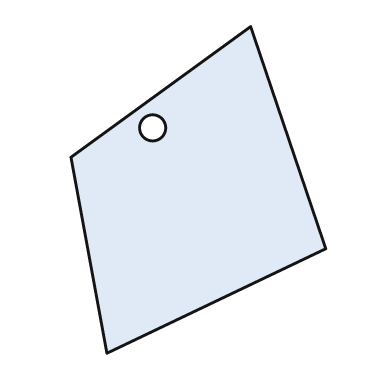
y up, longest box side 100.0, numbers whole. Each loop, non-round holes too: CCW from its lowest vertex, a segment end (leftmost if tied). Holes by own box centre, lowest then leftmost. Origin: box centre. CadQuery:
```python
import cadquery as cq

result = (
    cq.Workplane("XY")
    .moveTo(-28.0, -50.0)
    .lineTo(39.0, -18.0)
    .lineTo(16.0, 50.0)
    .lineTo(-39.0, 10.0)
    .close()
    .moveTo(-14.0, 19.0)
    .circle(4.0)
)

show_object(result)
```